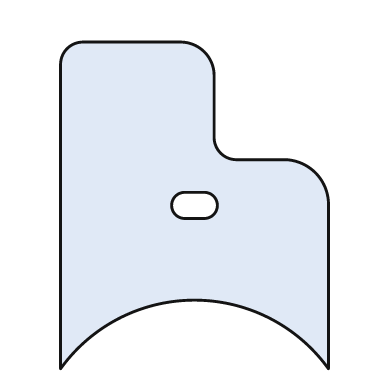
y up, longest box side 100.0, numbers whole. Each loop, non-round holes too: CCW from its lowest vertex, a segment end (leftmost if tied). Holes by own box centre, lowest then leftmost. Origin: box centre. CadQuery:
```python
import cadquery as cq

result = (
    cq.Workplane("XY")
    .moveTo(-41.0, -50.0)
    .threePointArc((0.0, -29.0), (41.0, -50.0))
    .lineTo(41.0, 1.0)
    .threePointArc((37.0, 10.0), (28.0, 14.0))
    .lineTo(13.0, 14.0)
    .threePointArc((8.0, 16.0), (6.0, 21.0))
    .lineTo(6.0, 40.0)
    .threePointArc((3.0, 47.0), (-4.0, 50.0))
    .lineTo(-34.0, 50.0)
    .threePointArc((-39.0, 48.0), (-41.0, 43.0))
    .close()
    .moveTo(-3.0, -4.0)
    .lineTo(3.0, -4.0)
    .threePointArc((7.0, 0.0), (3.0, 4.0))
    .lineTo(-3.0, 4.0)
    .threePointArc((-7.0, 0.0), (-3.0, -4.0))
    .close()
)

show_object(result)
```